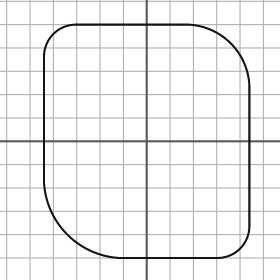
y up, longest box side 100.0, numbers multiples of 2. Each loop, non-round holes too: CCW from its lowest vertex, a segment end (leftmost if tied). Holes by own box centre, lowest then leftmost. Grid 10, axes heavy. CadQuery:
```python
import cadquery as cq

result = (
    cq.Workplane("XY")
    .moveTo(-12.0, -50.0)
    .lineTo(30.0, -50.0)
    .threePointArc((40.0, -46.0), (44.0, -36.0))
    .lineTo(44.0, 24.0)
    .threePointArc((36.0, 42.0), (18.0, 50.0))
    .lineTo(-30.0, 50.0)
    .threePointArc((-40.0, 46.0), (-44.0, 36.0))
    .lineTo(-44.0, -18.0)
    .threePointArc((-34.0, -40.0), (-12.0, -50.0))
    .close()
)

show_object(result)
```